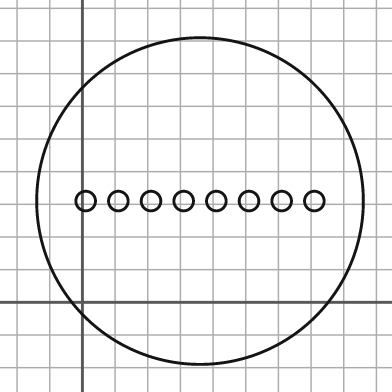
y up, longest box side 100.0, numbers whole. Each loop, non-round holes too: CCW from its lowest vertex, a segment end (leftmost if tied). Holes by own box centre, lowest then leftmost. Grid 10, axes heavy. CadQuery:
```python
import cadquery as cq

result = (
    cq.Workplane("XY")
    .moveTo(36.0, 31.0)
    .circle(50.0)
    .moveTo(1.0, 31.0)
    .circle(3.0)
    .moveTo(11.0, 31.0)
    .circle(3.0)
    .moveTo(21.0, 31.0)
    .circle(3.0)
    .moveTo(31.0, 31.0)
    .circle(3.0)
    .moveTo(41.0, 31.0)
    .circle(3.0)
    .moveTo(51.0, 31.0)
    .circle(3.0)
    .moveTo(61.0, 31.0)
    .circle(3.0)
    .moveTo(71.0, 31.0)
    .circle(3.0)
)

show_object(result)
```